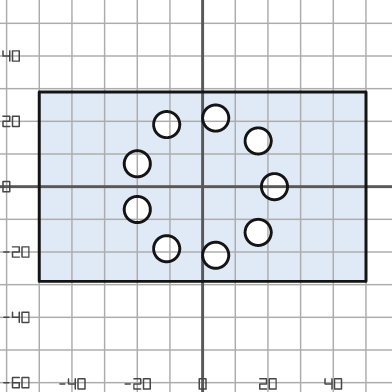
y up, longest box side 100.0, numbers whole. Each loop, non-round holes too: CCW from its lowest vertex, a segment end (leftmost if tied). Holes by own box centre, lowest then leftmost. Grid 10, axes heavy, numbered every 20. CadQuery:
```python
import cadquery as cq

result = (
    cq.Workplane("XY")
    .moveTo(-50.0, -29.0)
    .lineTo(50.0, -29.0)
    .lineTo(50.0, 29.0)
    .lineTo(-50.0, 29.0)
    .close()
    .moveTo(4.0, -21.0)
    .circle(4.0)
    .moveTo(-11.0, -19.0)
    .circle(4.0)
    .moveTo(17.0, -14.0)
    .circle(4.0)
    .moveTo(-20.0, -7.0)
    .circle(4.0)
    .moveTo(22.0, 0.0)
    .circle(4.0)
    .moveTo(-20.0, 7.0)
    .circle(4.0)
    .moveTo(17.0, 14.0)
    .circle(4.0)
    .moveTo(-11.0, 19.0)
    .circle(4.0)
    .moveTo(4.0, 21.0)
    .circle(4.0)
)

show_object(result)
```